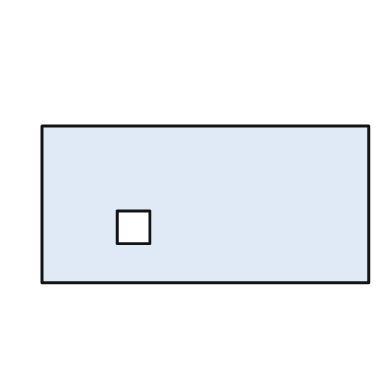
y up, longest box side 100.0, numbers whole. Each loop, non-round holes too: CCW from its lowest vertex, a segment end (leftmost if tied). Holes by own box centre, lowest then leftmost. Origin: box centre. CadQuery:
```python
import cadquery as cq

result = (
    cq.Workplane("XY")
    .moveTo(-50.0, -24.0)
    .lineTo(50.0, -24.0)
    .lineTo(50.0, 24.0)
    .lineTo(-50.0, 24.0)
    .close()
    .moveTo(-27.0, -12.0)
    .lineTo(-17.0, -12.0)
    .lineTo(-17.0, -2.0)
    .lineTo(-27.0, -2.0)
    .close()
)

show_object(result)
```